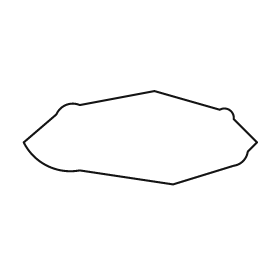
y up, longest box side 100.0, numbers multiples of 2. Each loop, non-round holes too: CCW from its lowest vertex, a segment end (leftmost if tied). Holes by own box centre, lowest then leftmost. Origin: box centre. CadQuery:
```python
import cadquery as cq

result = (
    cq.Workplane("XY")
    .moveTo(14.0, -20.0)
    .lineTo(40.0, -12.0)
    .threePointArc((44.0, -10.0), (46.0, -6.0))
    .lineTo(50.0, -2.0)
    .lineTo(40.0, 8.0)
    .threePointArc((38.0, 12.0), (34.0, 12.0))
    .lineTo(6.0, 20.0)
    .lineTo(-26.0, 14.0)
    .threePointArc((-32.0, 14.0), (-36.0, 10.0))
    .lineTo(-50.0, -2.0)
    .threePointArc((-40.0, -12.0), (-26.0, -14.0))
    .close()
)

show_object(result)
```